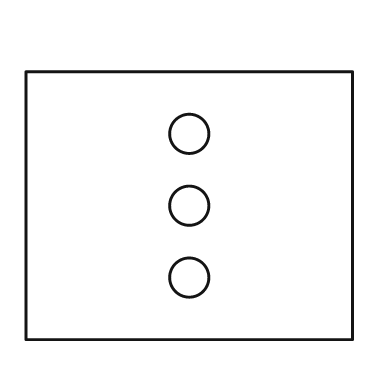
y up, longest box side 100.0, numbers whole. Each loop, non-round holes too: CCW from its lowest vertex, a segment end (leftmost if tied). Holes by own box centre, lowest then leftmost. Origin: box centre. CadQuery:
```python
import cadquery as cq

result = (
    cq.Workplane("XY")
    .moveTo(-50.0, -41.0)
    .lineTo(50.0, -41.0)
    .lineTo(50.0, 41.0)
    .lineTo(-50.0, 41.0)
    .close()
    .moveTo(0.0, -22.0)
    .circle(6.0)
    .moveTo(0.0, 0.0)
    .circle(6.0)
    .moveTo(0.0, 22.0)
    .circle(6.0)
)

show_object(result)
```